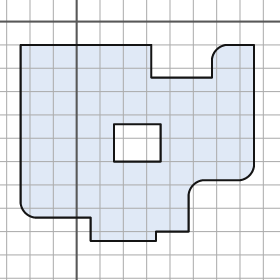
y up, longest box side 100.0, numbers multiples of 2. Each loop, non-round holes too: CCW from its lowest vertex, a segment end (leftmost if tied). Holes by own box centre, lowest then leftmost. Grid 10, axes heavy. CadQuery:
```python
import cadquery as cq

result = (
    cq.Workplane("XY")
    .moveTo(6.0, -94.0)
    .lineTo(34.0, -94.0)
    .lineTo(34.0, -90.0)
    .lineTo(48.0, -90.0)
    .lineTo(48.0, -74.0)
    .threePointArc((50.0, -70.0), (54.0, -68.0))
    .lineTo(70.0, -68.0)
    .threePointArc((74.0, -66.0), (76.0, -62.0))
    .lineTo(76.0, -10.0)
    .lineTo(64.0, -10.0)
    .threePointArc((60.0, -12.0), (58.0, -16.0))
    .lineTo(58.0, -24.0)
    .lineTo(32.0, -24.0)
    .lineTo(32.0, -10.0)
    .lineTo(-24.0, -10.0)
    .lineTo(-24.0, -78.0)
    .threePointArc((-22.0, -82.0), (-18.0, -84.0))
    .lineTo(6.0, -84.0)
    .close()
    .moveTo(16.0, -60.0)
    .lineTo(36.0, -60.0)
    .lineTo(36.0, -44.0)
    .lineTo(16.0, -44.0)
    .close()
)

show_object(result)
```